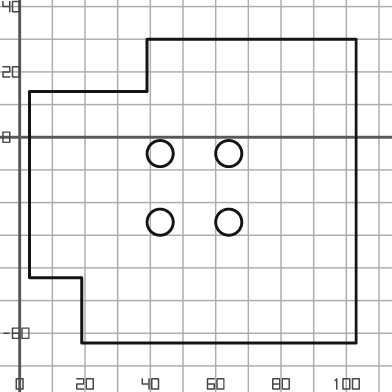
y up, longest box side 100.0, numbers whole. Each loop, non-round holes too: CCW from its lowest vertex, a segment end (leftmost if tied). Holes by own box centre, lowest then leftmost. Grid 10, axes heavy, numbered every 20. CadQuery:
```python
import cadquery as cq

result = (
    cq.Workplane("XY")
    .moveTo(19.0, -63.0)
    .lineTo(103.0, -63.0)
    .lineTo(103.0, 30.0)
    .lineTo(39.0, 30.0)
    .lineTo(39.0, 14.0)
    .lineTo(3.0, 14.0)
    .lineTo(3.0, -43.0)
    .lineTo(19.0, -43.0)
    .close()
    .moveTo(43.0, -26.0)
    .circle(4.0)
    .moveTo(64.0, -26.0)
    .circle(4.0)
    .moveTo(43.0, -5.0)
    .circle(4.0)
    .moveTo(64.0, -5.0)
    .circle(4.0)
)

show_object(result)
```